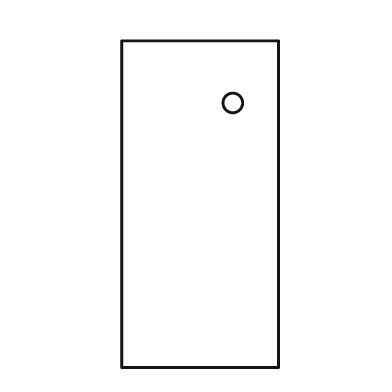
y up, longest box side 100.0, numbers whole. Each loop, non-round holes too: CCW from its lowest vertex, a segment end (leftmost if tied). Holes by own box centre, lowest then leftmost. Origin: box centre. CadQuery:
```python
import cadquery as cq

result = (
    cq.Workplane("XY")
    .moveTo(-24.0, -50.0)
    .lineTo(24.0, -50.0)
    .lineTo(24.0, 50.0)
    .lineTo(-24.0, 50.0)
    .close()
    .moveTo(10.0, 31.0)
    .circle(3.0)
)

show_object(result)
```